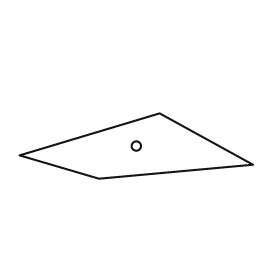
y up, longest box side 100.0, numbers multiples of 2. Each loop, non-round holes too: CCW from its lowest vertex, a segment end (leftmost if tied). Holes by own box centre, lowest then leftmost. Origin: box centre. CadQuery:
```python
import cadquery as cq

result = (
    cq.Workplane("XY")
    .moveTo(-16.0, -14.0)
    .lineTo(50.0, -8.0)
    .lineTo(10.0, 14.0)
    .lineTo(-50.0, -4.0)
    .close()
    .moveTo(0.0, 0.0)
    .circle(2.0)
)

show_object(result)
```